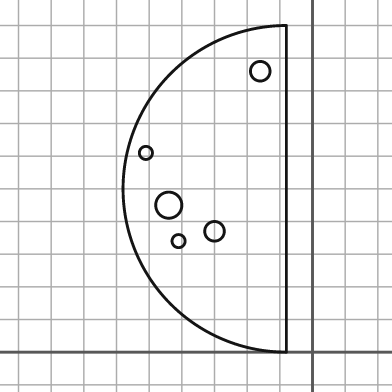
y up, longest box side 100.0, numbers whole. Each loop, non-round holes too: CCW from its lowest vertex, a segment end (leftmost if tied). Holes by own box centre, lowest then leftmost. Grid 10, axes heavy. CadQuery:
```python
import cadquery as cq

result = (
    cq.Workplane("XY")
    .moveTo(-8.0, 0.0)
    .lineTo(-8.0, 100.0)
    .threePointArc((-58.0, 50.0), (-8.0, 0.0))
    .close()
    .moveTo(-41.0, 34.0)
    .circle(2.0)
    .moveTo(-30.0, 37.0)
    .circle(3.0)
    .moveTo(-44.0, 45.0)
    .circle(4.0)
    .moveTo(-51.0, 61.0)
    .circle(2.0)
    .moveTo(-16.0, 86.0)
    .circle(3.0)
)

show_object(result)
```